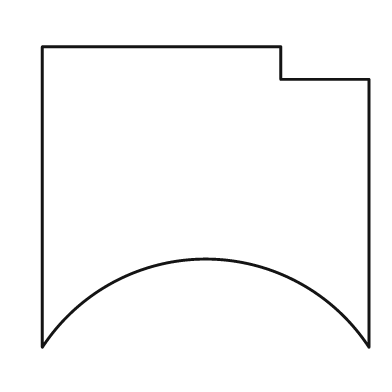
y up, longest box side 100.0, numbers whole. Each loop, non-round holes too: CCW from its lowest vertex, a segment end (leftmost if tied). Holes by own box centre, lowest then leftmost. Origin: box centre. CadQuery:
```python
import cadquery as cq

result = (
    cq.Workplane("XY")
    .moveTo(-50.0, -46.0)
    .threePointArc((0.0, -19.0), (50.0, -46.0))
    .lineTo(50.0, 36.0)
    .lineTo(23.0, 36.0)
    .lineTo(23.0, 46.0)
    .lineTo(-50.0, 46.0)
    .close()
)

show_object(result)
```